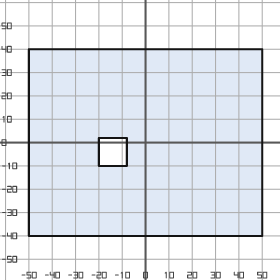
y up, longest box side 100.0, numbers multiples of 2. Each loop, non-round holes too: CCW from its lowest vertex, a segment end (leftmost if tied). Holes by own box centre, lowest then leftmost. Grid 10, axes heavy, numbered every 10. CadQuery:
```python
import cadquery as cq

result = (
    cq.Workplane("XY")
    .moveTo(-50.0, -40.0)
    .lineTo(50.0, -40.0)
    .lineTo(50.0, 40.0)
    .lineTo(-50.0, 40.0)
    .close()
    .moveTo(-20.0, -10.0)
    .lineTo(-8.0, -10.0)
    .lineTo(-8.0, 2.0)
    .lineTo(-20.0, 2.0)
    .close()
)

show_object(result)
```